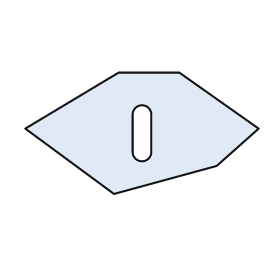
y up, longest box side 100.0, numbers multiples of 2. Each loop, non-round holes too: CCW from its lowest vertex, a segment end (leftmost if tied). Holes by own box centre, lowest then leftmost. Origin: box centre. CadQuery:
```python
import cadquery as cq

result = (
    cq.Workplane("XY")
    .moveTo(-12.0, -26.0)
    .lineTo(32.0, -14.0)
    .lineTo(50.0, 2.0)
    .lineTo(16.0, 26.0)
    .lineTo(-10.0, 26.0)
    .lineTo(-50.0, 2.0)
    .close()
    .moveTo(-4.0, -8.0)
    .threePointArc((0.0, -12.0), (4.0, -8.0))
    .lineTo(4.0, 8.0)
    .threePointArc((0.0, 12.0), (-4.0, 8.0))
    .close()
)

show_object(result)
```